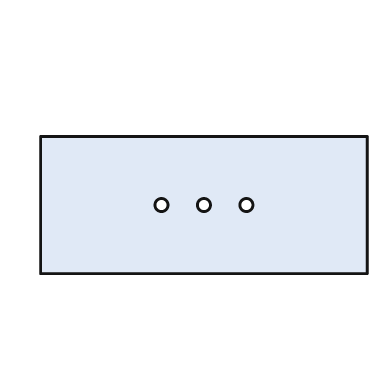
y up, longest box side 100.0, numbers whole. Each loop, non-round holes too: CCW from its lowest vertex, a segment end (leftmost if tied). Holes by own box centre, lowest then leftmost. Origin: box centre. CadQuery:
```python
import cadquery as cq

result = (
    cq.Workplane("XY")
    .moveTo(-50.0, -21.0)
    .lineTo(50.0, -21.0)
    .lineTo(50.0, 21.0)
    .lineTo(-50.0, 21.0)
    .close()
    .moveTo(-13.0, 0.0)
    .circle(2.0)
    .moveTo(0.0, 0.0)
    .circle(2.0)
    .moveTo(13.0, 0.0)
    .circle(2.0)
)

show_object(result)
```